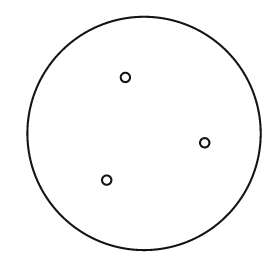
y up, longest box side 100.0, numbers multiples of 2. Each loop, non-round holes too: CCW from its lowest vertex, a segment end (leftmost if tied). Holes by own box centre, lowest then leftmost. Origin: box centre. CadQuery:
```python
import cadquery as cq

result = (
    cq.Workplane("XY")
    .moveTo(0.0, 0.0)
    .circle(50.0)
    .moveTo(-16.0, -20.0)
    .circle(2.0)
    .moveTo(26.0, -4.0)
    .circle(2.0)
    .moveTo(-8.0, 24.0)
    .circle(2.0)
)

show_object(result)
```